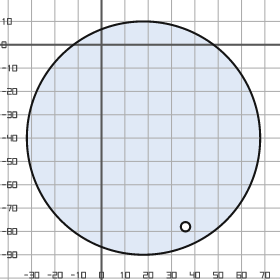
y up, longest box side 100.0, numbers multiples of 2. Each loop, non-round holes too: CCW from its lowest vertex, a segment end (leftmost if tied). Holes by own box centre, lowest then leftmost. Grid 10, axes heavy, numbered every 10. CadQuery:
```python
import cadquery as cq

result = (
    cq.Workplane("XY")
    .moveTo(18.0, -40.0)
    .circle(50.0)
    .moveTo(36.0, -78.0)
    .circle(2.0)
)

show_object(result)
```